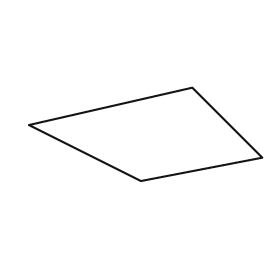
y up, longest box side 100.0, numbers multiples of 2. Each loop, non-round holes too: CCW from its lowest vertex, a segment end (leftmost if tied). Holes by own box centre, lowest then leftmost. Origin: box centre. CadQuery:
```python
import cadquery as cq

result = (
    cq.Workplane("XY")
    .moveTo(-2.0, -20.0)
    .lineTo(50.0, -10.0)
    .lineTo(20.0, 20.0)
    .lineTo(-50.0, 4.0)
    .close()
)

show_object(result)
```